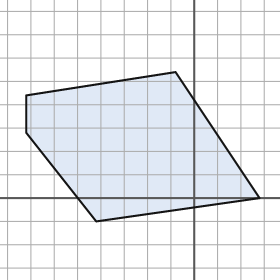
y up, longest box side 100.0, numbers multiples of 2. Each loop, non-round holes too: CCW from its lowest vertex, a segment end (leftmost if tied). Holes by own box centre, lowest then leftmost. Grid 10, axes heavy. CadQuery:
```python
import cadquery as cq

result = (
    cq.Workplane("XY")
    .moveTo(-42.0, -10.0)
    .lineTo(28.0, 0.0)
    .lineTo(-8.0, 54.0)
    .lineTo(-72.0, 44.0)
    .lineTo(-72.0, 28.0)
    .close()
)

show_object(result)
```